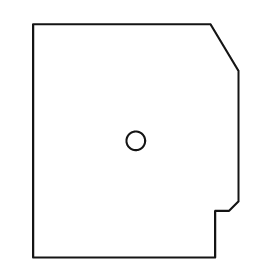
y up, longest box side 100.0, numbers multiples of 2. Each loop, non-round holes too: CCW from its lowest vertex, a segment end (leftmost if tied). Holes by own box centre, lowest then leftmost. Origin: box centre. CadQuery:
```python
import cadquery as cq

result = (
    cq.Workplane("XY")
    .moveTo(-44.0, -50.0)
    .lineTo(34.0, -50.0)
    .lineTo(34.0, -30.0)
    .lineTo(40.0, -30.0)
    .lineTo(44.0, -26.0)
    .lineTo(44.0, 30.0)
    .lineTo(32.0, 50.0)
    .lineTo(-44.0, 50.0)
    .close()
    .moveTo(0.0, 0.0)
    .circle(4.0)
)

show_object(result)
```